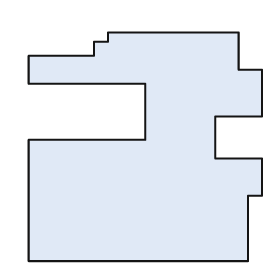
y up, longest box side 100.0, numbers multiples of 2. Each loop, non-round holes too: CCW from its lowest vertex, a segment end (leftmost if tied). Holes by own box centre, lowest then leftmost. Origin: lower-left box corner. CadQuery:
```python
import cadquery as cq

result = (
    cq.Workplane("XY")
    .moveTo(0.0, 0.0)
    .lineTo(94.0, 0.0)
    .lineTo(94.0, 28.0)
    .lineTo(100.0, 28.0)
    .lineTo(100.0, 44.0)
    .lineTo(80.0, 44.0)
    .lineTo(80.0, 62.0)
    .lineTo(100.0, 62.0)
    .lineTo(100.0, 82.0)
    .lineTo(90.0, 82.0)
    .lineTo(90.0, 98.0)
    .lineTo(34.0, 98.0)
    .lineTo(34.0, 94.0)
    .lineTo(28.0, 94.0)
    .lineTo(28.0, 88.0)
    .lineTo(0.0, 88.0)
    .lineTo(0.0, 76.0)
    .lineTo(50.0, 76.0)
    .lineTo(50.0, 52.0)
    .lineTo(0.0, 52.0)
    .close()
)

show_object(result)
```